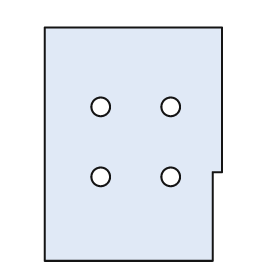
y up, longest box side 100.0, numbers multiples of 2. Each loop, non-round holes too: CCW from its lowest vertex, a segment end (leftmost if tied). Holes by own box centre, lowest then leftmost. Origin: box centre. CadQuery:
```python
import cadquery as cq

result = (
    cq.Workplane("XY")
    .moveTo(-38.0, -50.0)
    .lineTo(34.0, -50.0)
    .lineTo(34.0, -12.0)
    .lineTo(38.0, -12.0)
    .lineTo(38.0, 50.0)
    .lineTo(-38.0, 50.0)
    .close()
    .moveTo(-14.0, -14.0)
    .circle(4.0)
    .moveTo(16.0, -14.0)
    .circle(4.0)
    .moveTo(-14.0, 16.0)
    .circle(4.0)
    .moveTo(16.0, 16.0)
    .circle(4.0)
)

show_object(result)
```